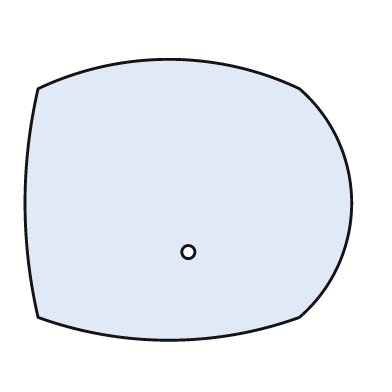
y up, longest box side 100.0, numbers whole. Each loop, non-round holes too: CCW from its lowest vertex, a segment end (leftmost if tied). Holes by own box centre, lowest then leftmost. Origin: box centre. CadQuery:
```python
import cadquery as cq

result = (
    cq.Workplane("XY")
    .moveTo(-46.0, -36.0)
    .threePointArc((-6.0, -43.0), (34.0, -36.0))
    .threePointArc((50.0, -1.0), (34.0, 34.0))
    .threePointArc((-6.0, 43.0), (-46.0, 34.0))
    .threePointArc((-50.0, -1.0), (-46.0, -36.0))
    .close()
    .moveTo(0.0, -16.0)
    .circle(2.0)
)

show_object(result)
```